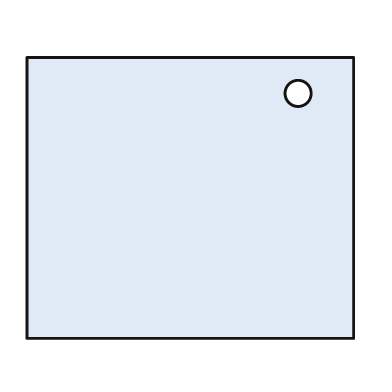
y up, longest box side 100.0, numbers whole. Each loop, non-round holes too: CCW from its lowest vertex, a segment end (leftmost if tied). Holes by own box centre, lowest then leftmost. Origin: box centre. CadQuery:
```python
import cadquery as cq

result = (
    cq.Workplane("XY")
    .moveTo(-50.0, -43.0)
    .lineTo(50.0, -43.0)
    .lineTo(50.0, 43.0)
    .lineTo(-50.0, 43.0)
    .close()
    .moveTo(33.0, 32.0)
    .circle(4.0)
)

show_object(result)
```